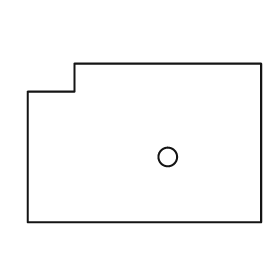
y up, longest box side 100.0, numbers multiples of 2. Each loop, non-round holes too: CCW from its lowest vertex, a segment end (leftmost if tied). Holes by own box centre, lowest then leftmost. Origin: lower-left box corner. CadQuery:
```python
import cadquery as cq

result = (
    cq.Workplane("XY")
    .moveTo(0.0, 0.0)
    .lineTo(100.0, 0.0)
    .lineTo(100.0, 68.0)
    .lineTo(20.0, 68.0)
    .lineTo(20.0, 56.0)
    .lineTo(0.0, 56.0)
    .close()
    .moveTo(60.0, 28.0)
    .circle(4.0)
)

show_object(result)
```